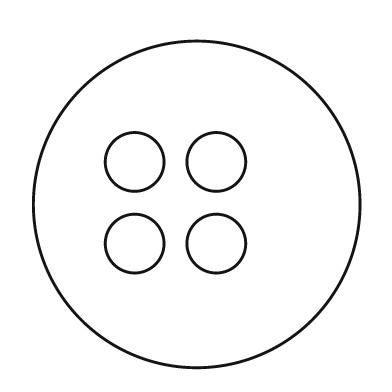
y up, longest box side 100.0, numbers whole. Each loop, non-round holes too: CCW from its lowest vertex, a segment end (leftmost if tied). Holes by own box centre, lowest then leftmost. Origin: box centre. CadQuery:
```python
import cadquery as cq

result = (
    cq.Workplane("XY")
    .moveTo(0.0, 0.0)
    .circle(50.0)
    .moveTo(-19.0, -12.0)
    .circle(9.0)
    .moveTo(6.0, -12.0)
    .circle(9.0)
    .moveTo(-19.0, 13.0)
    .circle(9.0)
    .moveTo(6.0, 13.0)
    .circle(9.0)
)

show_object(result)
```